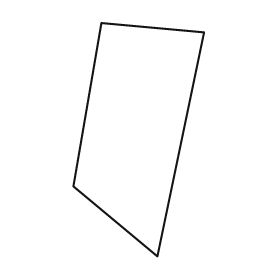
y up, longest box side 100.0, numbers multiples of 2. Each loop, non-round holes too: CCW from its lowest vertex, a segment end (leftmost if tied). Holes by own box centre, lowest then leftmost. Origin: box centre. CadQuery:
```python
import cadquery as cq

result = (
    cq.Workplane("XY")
    .moveTo(8.0, -50.0)
    .lineTo(28.0, 46.0)
    .lineTo(-16.0, 50.0)
    .lineTo(-28.0, -20.0)
    .close()
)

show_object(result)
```